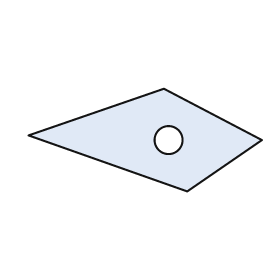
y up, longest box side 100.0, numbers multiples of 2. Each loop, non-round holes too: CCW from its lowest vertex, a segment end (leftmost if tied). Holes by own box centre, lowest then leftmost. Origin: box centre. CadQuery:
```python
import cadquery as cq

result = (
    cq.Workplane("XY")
    .moveTo(18.0, -22.0)
    .lineTo(50.0, 0.0)
    .lineTo(8.0, 22.0)
    .lineTo(-50.0, 2.0)
    .close()
    .moveTo(10.0, 0.0)
    .circle(6.0)
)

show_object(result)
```